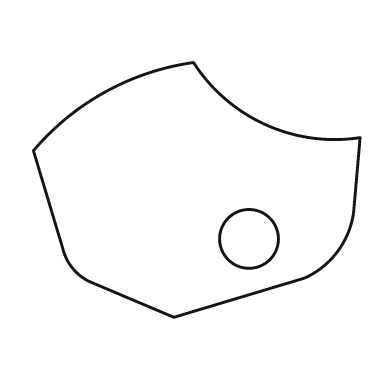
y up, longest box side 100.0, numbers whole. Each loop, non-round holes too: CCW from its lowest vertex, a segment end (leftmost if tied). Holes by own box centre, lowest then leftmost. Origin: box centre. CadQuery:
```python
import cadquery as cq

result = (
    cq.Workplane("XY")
    .moveTo(-7.0, -39.0)
    .lineTo(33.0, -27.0)
    .threePointArc((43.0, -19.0), (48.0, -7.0))
    .lineTo(50.0, 16.0)
    .threePointArc((21.0, 20.0), (-1.0, 39.0))
    .threePointArc((-28.0, 30.0), (-50.0, 12.0))
    .lineTo(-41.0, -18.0)
    .threePointArc((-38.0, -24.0), (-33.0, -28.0))
    .close()
    .moveTo(16.0, -15.0)
    .circle(9.0)
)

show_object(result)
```